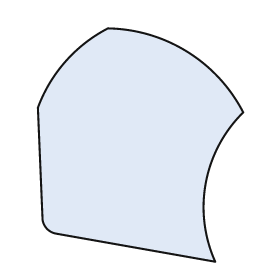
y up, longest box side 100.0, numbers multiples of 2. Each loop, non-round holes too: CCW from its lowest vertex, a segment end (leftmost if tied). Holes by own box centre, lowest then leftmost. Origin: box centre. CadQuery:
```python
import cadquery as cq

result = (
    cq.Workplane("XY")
    .moveTo(32.0, -50.0)
    .threePointArc((28.0, -16.0), (44.0, 14.0))
    .threePointArc((20.0, 40.0), (-14.0, 50.0))
    .threePointArc((-32.0, 36.0), (-44.0, 16.0))
    .lineTo(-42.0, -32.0)
    .threePointArc((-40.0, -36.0), (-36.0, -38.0))
    .close()
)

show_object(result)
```